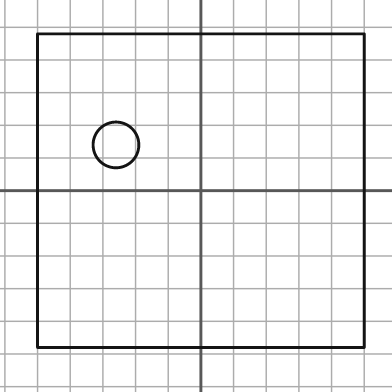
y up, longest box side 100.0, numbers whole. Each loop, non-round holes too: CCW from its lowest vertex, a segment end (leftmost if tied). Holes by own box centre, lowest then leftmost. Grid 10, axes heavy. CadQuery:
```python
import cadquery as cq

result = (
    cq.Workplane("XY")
    .moveTo(-50.0, -48.0)
    .lineTo(50.0, -48.0)
    .lineTo(50.0, 48.0)
    .lineTo(-50.0, 48.0)
    .close()
    .moveTo(-26.0, 14.0)
    .circle(7.0)
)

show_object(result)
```